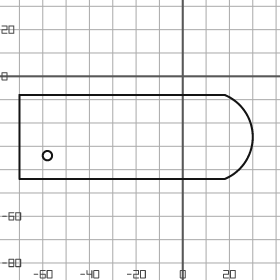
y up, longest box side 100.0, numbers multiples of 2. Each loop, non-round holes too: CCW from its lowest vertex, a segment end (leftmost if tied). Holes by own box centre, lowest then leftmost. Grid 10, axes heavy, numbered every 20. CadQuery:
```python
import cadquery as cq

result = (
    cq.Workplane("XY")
    .moveTo(-70.0, -44.0)
    .lineTo(18.0, -44.0)
    .threePointArc((30.0, -26.0), (18.0, -8.0))
    .lineTo(-70.0, -8.0)
    .close()
    .moveTo(-58.0, -34.0)
    .circle(2.0)
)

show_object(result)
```